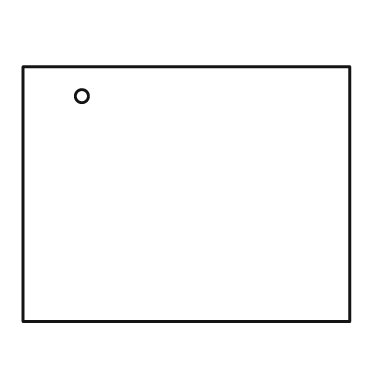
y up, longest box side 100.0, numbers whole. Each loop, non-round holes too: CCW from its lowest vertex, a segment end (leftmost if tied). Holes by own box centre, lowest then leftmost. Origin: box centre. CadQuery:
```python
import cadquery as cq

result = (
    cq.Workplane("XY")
    .moveTo(-50.0, -39.0)
    .lineTo(50.0, -39.0)
    .lineTo(50.0, 39.0)
    .lineTo(-50.0, 39.0)
    .close()
    .moveTo(-32.0, 30.0)
    .circle(2.0)
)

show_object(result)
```